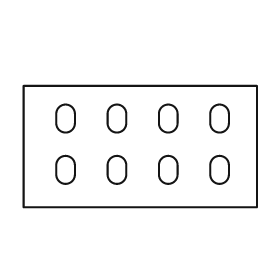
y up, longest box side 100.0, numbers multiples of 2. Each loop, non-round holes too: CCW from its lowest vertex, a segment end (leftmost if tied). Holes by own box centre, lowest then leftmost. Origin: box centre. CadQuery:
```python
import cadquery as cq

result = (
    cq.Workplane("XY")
    .moveTo(-50.0, -26.0)
    .lineTo(50.0, -26.0)
    .lineTo(50.0, 26.0)
    .lineTo(-50.0, 26.0)
    .close()
    .moveTo(-36.0, -12.0)
    .threePointArc((-32.0, -16.0), (-28.0, -12.0))
    .lineTo(-28.0, -8.0)
    .threePointArc((-32.0, -4.0), (-36.0, -8.0))
    .close()
    .moveTo(-14.0, -12.0)
    .threePointArc((-10.0, -16.0), (-6.0, -12.0))
    .lineTo(-6.0, -8.0)
    .threePointArc((-10.0, -4.0), (-14.0, -8.0))
    .close()
    .moveTo(8.0, -12.0)
    .threePointArc((12.0, -16.0), (16.0, -12.0))
    .lineTo(16.0, -8.0)
    .threePointArc((12.0, -4.0), (8.0, -8.0))
    .close()
    .moveTo(30.0, -12.0)
    .threePointArc((34.0, -16.0), (38.0, -12.0))
    .lineTo(38.0, -8.0)
    .threePointArc((34.0, -4.0), (30.0, -8.0))
    .close()
    .moveTo(-36.0, 10.0)
    .threePointArc((-32.0, 6.0), (-28.0, 10.0))
    .lineTo(-28.0, 14.0)
    .threePointArc((-32.0, 18.0), (-36.0, 14.0))
    .close()
    .moveTo(-14.0, 10.0)
    .threePointArc((-10.0, 6.0), (-6.0, 10.0))
    .lineTo(-6.0, 14.0)
    .threePointArc((-10.0, 18.0), (-14.0, 14.0))
    .close()
    .moveTo(8.0, 10.0)
    .threePointArc((12.0, 6.0), (16.0, 10.0))
    .lineTo(16.0, 14.0)
    .threePointArc((12.0, 18.0), (8.0, 14.0))
    .close()
    .moveTo(30.0, 10.0)
    .threePointArc((34.0, 6.0), (38.0, 10.0))
    .lineTo(38.0, 14.0)
    .threePointArc((34.0, 18.0), (30.0, 14.0))
    .close()
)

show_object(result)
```